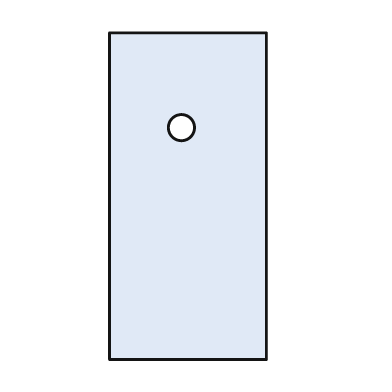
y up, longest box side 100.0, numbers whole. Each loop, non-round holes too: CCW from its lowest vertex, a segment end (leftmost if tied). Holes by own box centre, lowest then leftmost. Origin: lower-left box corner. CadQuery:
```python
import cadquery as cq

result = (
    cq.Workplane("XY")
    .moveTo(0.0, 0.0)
    .lineTo(48.0, 0.0)
    .lineTo(48.0, 100.0)
    .lineTo(0.0, 100.0)
    .close()
    .moveTo(22.0, 71.0)
    .circle(4.0)
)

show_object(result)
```